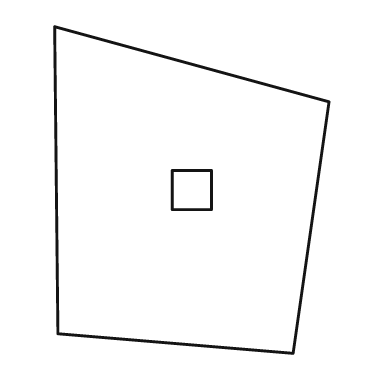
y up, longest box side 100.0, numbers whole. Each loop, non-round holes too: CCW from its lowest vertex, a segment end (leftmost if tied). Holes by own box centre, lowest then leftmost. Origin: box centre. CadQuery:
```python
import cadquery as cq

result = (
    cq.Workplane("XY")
    .moveTo(31.0, -50.0)
    .lineTo(42.0, 27.0)
    .lineTo(-42.0, 50.0)
    .lineTo(-41.0, -44.0)
    .close()
    .moveTo(-6.0, -6.0)
    .lineTo(6.0, -6.0)
    .lineTo(6.0, 6.0)
    .lineTo(-6.0, 6.0)
    .close()
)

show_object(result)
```